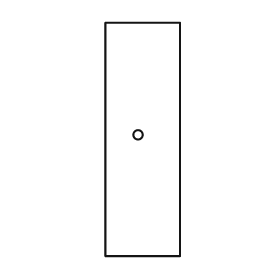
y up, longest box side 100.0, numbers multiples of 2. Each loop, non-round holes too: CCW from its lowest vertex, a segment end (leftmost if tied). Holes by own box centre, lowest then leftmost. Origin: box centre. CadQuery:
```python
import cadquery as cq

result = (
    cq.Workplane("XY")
    .moveTo(-16.0, -50.0)
    .lineTo(16.0, -50.0)
    .lineTo(16.0, 50.0)
    .lineTo(-16.0, 50.0)
    .close()
    .moveTo(-2.0, 2.0)
    .circle(2.0)
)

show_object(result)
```